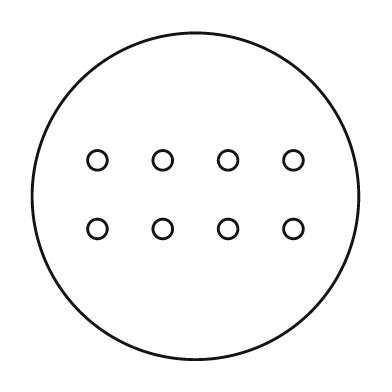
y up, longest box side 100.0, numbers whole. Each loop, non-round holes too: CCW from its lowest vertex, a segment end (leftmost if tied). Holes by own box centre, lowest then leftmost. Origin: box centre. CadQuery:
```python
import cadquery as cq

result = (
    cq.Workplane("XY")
    .moveTo(0.0, 0.0)
    .circle(50.0)
    .moveTo(-30.0, -10.0)
    .circle(3.0)
    .moveTo(-10.0, -10.0)
    .circle(3.0)
    .moveTo(10.0, -10.0)
    .circle(3.0)
    .moveTo(30.0, -10.0)
    .circle(3.0)
    .moveTo(-30.0, 11.0)
    .circle(3.0)
    .moveTo(-10.0, 11.0)
    .circle(3.0)
    .moveTo(10.0, 11.0)
    .circle(3.0)
    .moveTo(30.0, 11.0)
    .circle(3.0)
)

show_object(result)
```